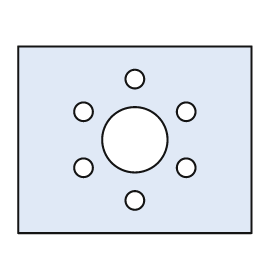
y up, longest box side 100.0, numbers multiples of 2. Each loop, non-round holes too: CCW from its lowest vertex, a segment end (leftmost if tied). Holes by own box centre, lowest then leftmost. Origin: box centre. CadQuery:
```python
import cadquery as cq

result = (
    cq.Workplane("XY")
    .moveTo(-50.0, -40.0)
    .lineTo(50.0, -40.0)
    .lineTo(50.0, 40.0)
    .lineTo(-50.0, 40.0)
    .close()
    .moveTo(0.0, -26.0)
    .circle(4.0)
    .moveTo(-22.0, -12.0)
    .circle(4.0)
    .moveTo(22.0, -12.0)
    .circle(4.0)
    .moveTo(0.0, 0.0)
    .circle(14.0)
    .moveTo(-22.0, 12.0)
    .circle(4.0)
    .moveTo(22.0, 12.0)
    .circle(4.0)
    .moveTo(0.0, 26.0)
    .circle(4.0)
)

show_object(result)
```